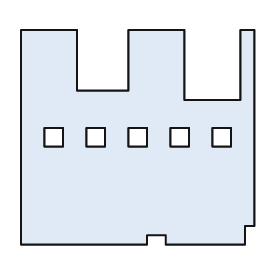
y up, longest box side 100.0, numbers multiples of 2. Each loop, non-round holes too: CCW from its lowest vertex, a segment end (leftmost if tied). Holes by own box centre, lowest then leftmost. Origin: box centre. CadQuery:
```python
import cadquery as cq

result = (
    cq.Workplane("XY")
    .moveTo(-50.0, -46.0)
    .lineTo(4.0, -46.0)
    .lineTo(4.0, -42.0)
    .lineTo(12.0, -42.0)
    .lineTo(12.0, -46.0)
    .lineTo(46.0, -46.0)
    .lineTo(46.0, -38.0)
    .lineTo(50.0, -38.0)
    .lineTo(50.0, 46.0)
    .lineTo(44.0, 46.0)
    .lineTo(44.0, 16.0)
    .lineTo(20.0, 16.0)
    .lineTo(20.0, 46.0)
    .lineTo(-4.0, 46.0)
    .lineTo(-4.0, 20.0)
    .lineTo(-26.0, 20.0)
    .lineTo(-26.0, 46.0)
    .lineTo(-50.0, 46.0)
    .close()
    .moveTo(-40.0, -4.0)
    .lineTo(-32.0, -4.0)
    .lineTo(-32.0, 4.0)
    .lineTo(-40.0, 4.0)
    .close()
    .moveTo(-22.0, -4.0)
    .lineTo(-14.0, -4.0)
    .lineTo(-14.0, 4.0)
    .lineTo(-22.0, 4.0)
    .close()
    .moveTo(-4.0, -4.0)
    .lineTo(4.0, -4.0)
    .lineTo(4.0, 4.0)
    .lineTo(-4.0, 4.0)
    .close()
    .moveTo(14.0, -4.0)
    .lineTo(22.0, -4.0)
    .lineTo(22.0, 4.0)
    .lineTo(14.0, 4.0)
    .close()
    .moveTo(32.0, -4.0)
    .lineTo(40.0, -4.0)
    .lineTo(40.0, 4.0)
    .lineTo(32.0, 4.0)
    .close()
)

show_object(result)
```